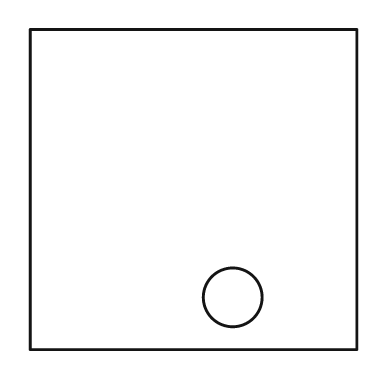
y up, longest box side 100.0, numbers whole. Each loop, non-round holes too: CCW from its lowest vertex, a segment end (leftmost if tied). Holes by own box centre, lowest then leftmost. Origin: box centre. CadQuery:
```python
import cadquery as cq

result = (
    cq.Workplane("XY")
    .moveTo(-50.0, -49.0)
    .lineTo(50.0, -49.0)
    .lineTo(50.0, 49.0)
    .lineTo(-50.0, 49.0)
    .close()
    .moveTo(12.0, -33.0)
    .circle(9.0)
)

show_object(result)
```